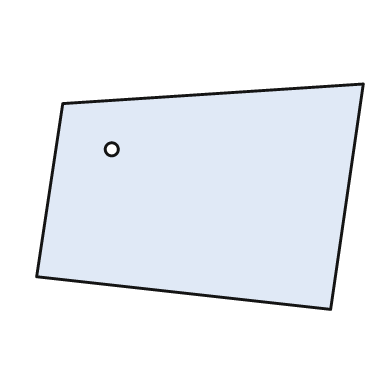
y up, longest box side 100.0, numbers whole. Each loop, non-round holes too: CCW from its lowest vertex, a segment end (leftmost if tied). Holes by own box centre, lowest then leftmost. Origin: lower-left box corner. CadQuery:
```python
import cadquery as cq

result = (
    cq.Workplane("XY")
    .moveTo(90.0, 0.0)
    .lineTo(100.0, 69.0)
    .lineTo(8.0, 63.0)
    .lineTo(0.0, 10.0)
    .close()
    .moveTo(23.0, 49.0)
    .circle(2.0)
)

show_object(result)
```